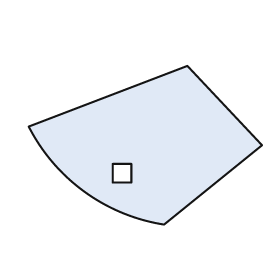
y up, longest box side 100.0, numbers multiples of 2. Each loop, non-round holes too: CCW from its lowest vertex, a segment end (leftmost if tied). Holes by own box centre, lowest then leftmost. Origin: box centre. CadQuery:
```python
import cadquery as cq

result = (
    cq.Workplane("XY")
    .moveTo(8.0, -34.0)
    .lineTo(50.0, 0.0)
    .lineTo(18.0, 34.0)
    .lineTo(-50.0, 8.0)
    .threePointArc((-26.0, -20.0), (8.0, -34.0))
    .close()
    .moveTo(-14.0, -16.0)
    .lineTo(-6.0, -16.0)
    .lineTo(-6.0, -8.0)
    .lineTo(-14.0, -8.0)
    .close()
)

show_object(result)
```